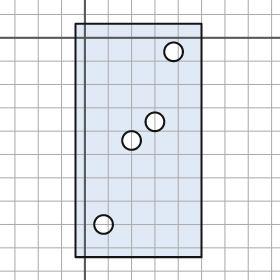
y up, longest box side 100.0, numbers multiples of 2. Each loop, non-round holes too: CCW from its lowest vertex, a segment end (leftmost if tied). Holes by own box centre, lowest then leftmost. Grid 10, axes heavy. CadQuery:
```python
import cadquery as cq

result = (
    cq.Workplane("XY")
    .moveTo(-4.0, -94.0)
    .lineTo(50.0, -94.0)
    .lineTo(50.0, 6.0)
    .lineTo(-4.0, 6.0)
    .close()
    .moveTo(8.0, -80.0)
    .circle(4.0)
    .moveTo(20.0, -44.0)
    .circle(4.0)
    .moveTo(30.0, -36.0)
    .circle(4.0)
    .moveTo(38.0, -6.0)
    .circle(4.0)
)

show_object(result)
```